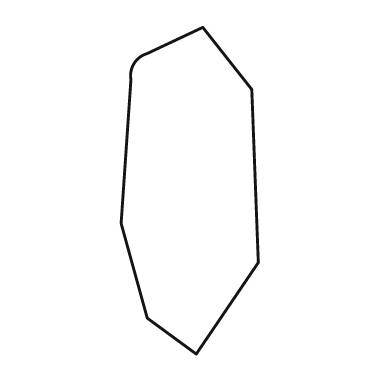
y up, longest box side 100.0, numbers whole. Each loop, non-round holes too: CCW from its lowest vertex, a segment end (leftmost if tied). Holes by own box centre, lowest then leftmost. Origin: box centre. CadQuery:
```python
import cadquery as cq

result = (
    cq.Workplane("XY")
    .moveTo(2.0, -50.0)
    .lineTo(21.0, -22.0)
    .lineTo(19.0, 31.0)
    .lineTo(4.0, 50.0)
    .lineTo(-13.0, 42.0)
    .threePointArc((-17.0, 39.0), (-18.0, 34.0))
    .lineTo(-21.0, -10.0)
    .lineTo(-13.0, -39.0)
    .close()
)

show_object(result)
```